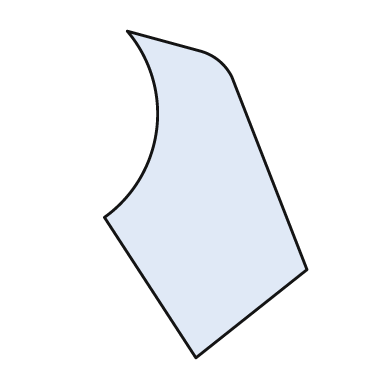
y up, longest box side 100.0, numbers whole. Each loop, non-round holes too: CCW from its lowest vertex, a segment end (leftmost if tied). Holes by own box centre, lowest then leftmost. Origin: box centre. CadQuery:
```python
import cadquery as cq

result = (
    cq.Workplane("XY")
    .moveTo(-3.0, -50.0)
    .lineTo(31.0, -23.0)
    .lineTo(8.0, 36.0)
    .threePointArc((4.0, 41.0), (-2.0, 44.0))
    .lineTo(-24.0, 50.0)
    .threePointArc((-15.0, 20.0), (-31.0, -7.0))
    .close()
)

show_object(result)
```